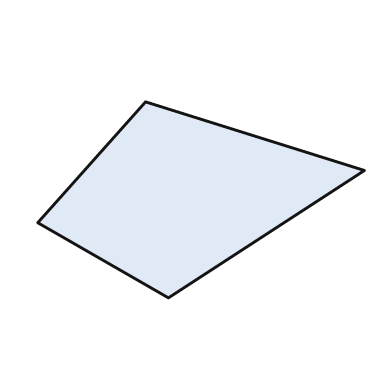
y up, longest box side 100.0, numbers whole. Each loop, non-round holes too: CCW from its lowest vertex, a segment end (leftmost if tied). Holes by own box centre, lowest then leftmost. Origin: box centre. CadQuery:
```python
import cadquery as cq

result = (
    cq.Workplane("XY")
    .moveTo(-10.0, -30.0)
    .lineTo(50.0, 9.0)
    .lineTo(-17.0, 30.0)
    .lineTo(-50.0, -7.0)
    .close()
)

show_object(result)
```